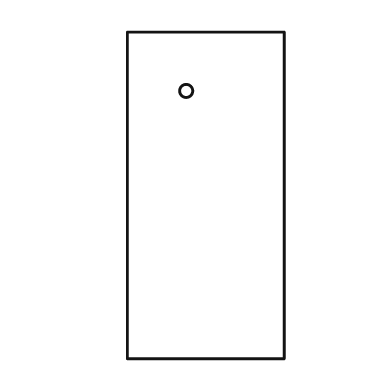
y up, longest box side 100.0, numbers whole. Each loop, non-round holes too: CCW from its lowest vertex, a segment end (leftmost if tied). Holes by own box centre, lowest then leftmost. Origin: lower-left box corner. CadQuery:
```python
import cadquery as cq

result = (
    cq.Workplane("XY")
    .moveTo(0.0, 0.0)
    .lineTo(48.0, 0.0)
    .lineTo(48.0, 100.0)
    .lineTo(0.0, 100.0)
    .close()
    .moveTo(18.0, 82.0)
    .circle(2.0)
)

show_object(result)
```